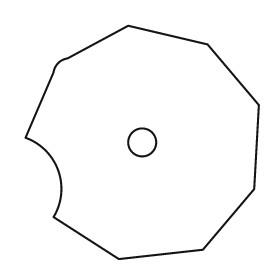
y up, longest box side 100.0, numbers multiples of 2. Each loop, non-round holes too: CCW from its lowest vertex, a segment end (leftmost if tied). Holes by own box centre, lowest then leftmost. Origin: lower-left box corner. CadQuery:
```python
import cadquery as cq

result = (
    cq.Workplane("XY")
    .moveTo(40.0, 0.0)
    .lineTo(76.0, 4.0)
    .lineTo(98.0, 30.0)
    .lineTo(100.0, 66.0)
    .lineTo(78.0, 92.0)
    .lineTo(44.0, 100.0)
    .lineTo(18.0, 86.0)
    .threePointArc((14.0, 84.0), (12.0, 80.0))
    .lineTo(0.0, 52.0)
    .threePointArc((14.0, 38.0), (12.0, 18.0))
    .close()
    .moveTo(50.0, 50.0)
    .circle(6.0)
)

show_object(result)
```